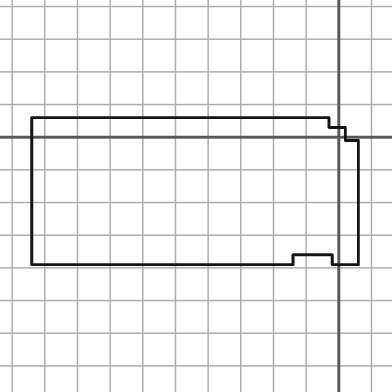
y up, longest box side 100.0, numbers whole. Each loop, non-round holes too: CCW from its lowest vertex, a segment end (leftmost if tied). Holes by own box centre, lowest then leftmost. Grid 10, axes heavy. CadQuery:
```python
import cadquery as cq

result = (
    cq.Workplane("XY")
    .moveTo(-94.0, -39.0)
    .lineTo(-14.0, -39.0)
    .lineTo(-14.0, -36.0)
    .lineTo(-2.0, -36.0)
    .lineTo(-2.0, -39.0)
    .lineTo(6.0, -39.0)
    .lineTo(6.0, -1.0)
    .lineTo(2.0, -1.0)
    .lineTo(2.0, 3.0)
    .lineTo(-3.0, 3.0)
    .lineTo(-3.0, 6.0)
    .lineTo(-94.0, 6.0)
    .close()
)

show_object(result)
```